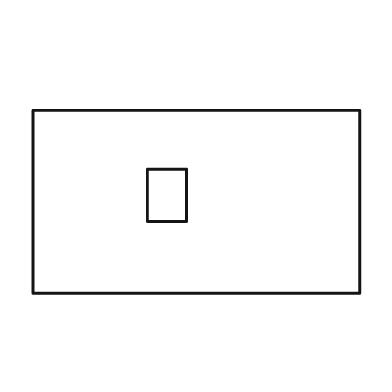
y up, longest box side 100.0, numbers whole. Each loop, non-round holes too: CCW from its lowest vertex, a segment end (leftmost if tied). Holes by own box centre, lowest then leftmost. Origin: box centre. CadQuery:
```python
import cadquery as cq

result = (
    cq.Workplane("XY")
    .moveTo(-50.0, -28.0)
    .lineTo(50.0, -28.0)
    .lineTo(50.0, 28.0)
    .lineTo(-50.0, 28.0)
    .close()
    .moveTo(-15.0, -6.0)
    .lineTo(-3.0, -6.0)
    .lineTo(-3.0, 10.0)
    .lineTo(-15.0, 10.0)
    .close()
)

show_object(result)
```